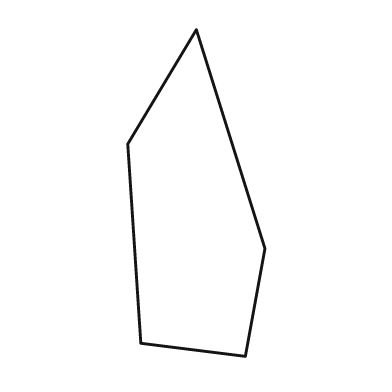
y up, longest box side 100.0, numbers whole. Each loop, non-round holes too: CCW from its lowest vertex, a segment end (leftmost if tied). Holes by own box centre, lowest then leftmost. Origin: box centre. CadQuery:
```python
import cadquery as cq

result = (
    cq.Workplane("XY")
    .moveTo(15.0, -50.0)
    .lineTo(21.0, -17.0)
    .lineTo(0.0, 50.0)
    .lineTo(-21.0, 15.0)
    .lineTo(-17.0, -46.0)
    .close()
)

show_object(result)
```